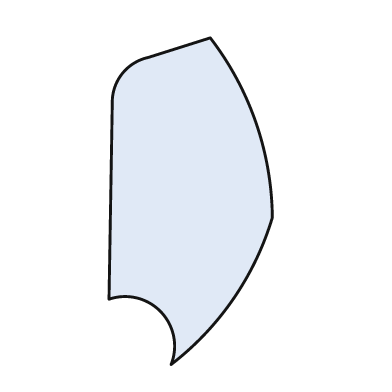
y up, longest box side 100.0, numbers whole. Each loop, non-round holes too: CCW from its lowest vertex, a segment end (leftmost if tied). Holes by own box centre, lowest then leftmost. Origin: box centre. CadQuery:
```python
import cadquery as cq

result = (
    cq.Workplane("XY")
    .moveTo(-6.0, -50.0)
    .threePointArc((13.0, -30.0), (25.0, -5.0))
    .threePointArc((20.0, 24.0), (6.0, 50.0))
    .lineTo(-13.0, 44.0)
    .threePointArc((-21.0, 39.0), (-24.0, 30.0))
    .lineTo(-25.0, -30.0)
    .threePointArc((-9.0, -34.0), (-6.0, -50.0))
    .close()
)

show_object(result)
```